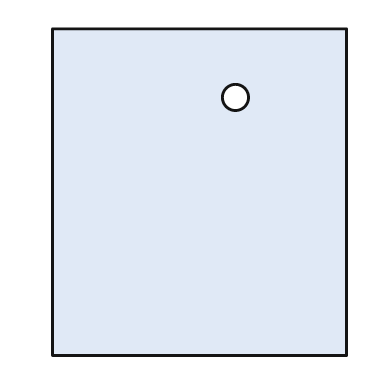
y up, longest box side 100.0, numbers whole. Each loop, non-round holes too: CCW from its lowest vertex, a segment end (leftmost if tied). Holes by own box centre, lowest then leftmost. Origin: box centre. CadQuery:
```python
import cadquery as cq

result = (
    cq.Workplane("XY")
    .moveTo(-45.0, -50.0)
    .lineTo(45.0, -50.0)
    .lineTo(45.0, 50.0)
    .lineTo(-45.0, 50.0)
    .close()
    .moveTo(11.0, 29.0)
    .circle(4.0)
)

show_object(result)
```